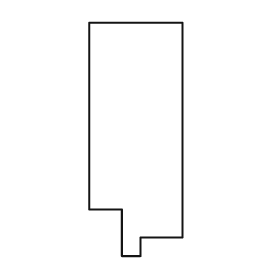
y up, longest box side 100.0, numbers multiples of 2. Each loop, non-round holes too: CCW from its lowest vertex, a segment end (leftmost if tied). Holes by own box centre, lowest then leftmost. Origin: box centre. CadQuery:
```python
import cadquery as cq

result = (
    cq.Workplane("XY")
    .moveTo(-6.0, -50.0)
    .lineTo(2.0, -50.0)
    .lineTo(2.0, -42.0)
    .lineTo(20.0, -42.0)
    .lineTo(20.0, 50.0)
    .lineTo(-20.0, 50.0)
    .lineTo(-20.0, -30.0)
    .lineTo(-6.0, -30.0)
    .close()
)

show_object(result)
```